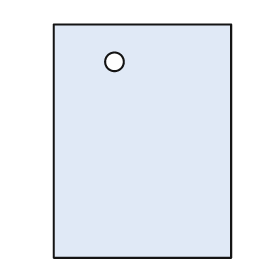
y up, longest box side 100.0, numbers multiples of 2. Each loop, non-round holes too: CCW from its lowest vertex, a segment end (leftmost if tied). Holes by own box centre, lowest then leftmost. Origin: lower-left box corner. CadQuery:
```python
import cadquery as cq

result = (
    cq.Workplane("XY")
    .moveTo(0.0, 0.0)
    .lineTo(76.0, 0.0)
    .lineTo(76.0, 100.0)
    .lineTo(0.0, 100.0)
    .close()
    .moveTo(26.0, 84.0)
    .circle(4.0)
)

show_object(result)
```